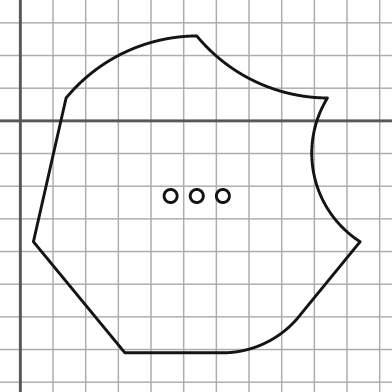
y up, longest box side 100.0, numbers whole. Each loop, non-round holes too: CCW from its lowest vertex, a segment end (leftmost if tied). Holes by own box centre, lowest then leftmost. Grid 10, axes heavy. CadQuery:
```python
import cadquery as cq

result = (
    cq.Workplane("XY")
    .moveTo(32.0, -71.0)
    .lineTo(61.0, -71.0)
    .threePointArc((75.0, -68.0), (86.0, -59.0))
    .lineTo(104.0, -37.0)
    .threePointArc((90.0, -17.0), (94.0, 7.0))
    .threePointArc((72.0, 12.0), (54.0, 26.0))
    .threePointArc((32.0, 21.0), (14.0, 7.0))
    .lineTo(4.0, -37.0)
    .close()
    .moveTo(46.0, -23.0)
    .circle(2.0)
    .moveTo(54.0, -23.0)
    .circle(2.0)
    .moveTo(62.0, -23.0)
    .circle(2.0)
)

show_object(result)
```